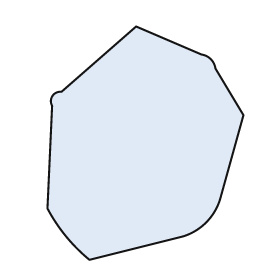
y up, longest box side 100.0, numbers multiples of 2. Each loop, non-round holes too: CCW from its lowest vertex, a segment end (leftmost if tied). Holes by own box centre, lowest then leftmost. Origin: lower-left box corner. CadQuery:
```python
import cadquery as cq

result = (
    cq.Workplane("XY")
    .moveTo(18.0, 0.0)
    .lineTo(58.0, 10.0)
    .threePointArc((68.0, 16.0), (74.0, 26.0))
    .lineTo(84.0, 62.0)
    .lineTo(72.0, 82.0)
    .threePointArc((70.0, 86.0), (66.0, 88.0))
    .lineTo(38.0, 100.0)
    .lineTo(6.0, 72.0)
    .threePointArc((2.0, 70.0), (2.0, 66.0))
    .lineTo(0.0, 22.0)
    .threePointArc((8.0, 10.0), (18.0, 0.0))
    .close()
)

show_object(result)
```